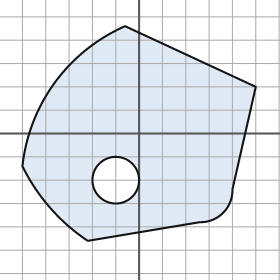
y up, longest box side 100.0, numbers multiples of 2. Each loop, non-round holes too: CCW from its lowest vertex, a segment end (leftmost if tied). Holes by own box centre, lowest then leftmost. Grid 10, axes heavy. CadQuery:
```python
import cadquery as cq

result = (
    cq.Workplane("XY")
    .moveTo(-22.0, -46.0)
    .lineTo(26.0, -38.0)
    .threePointArc((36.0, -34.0), (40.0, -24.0))
    .lineTo(50.0, 20.0)
    .lineTo(-6.0, 46.0)
    .threePointArc((-36.0, 22.0), (-50.0, -14.0))
    .threePointArc((-38.0, -32.0), (-22.0, -46.0))
    .close()
    .moveTo(-10.0, -20.0)
    .circle(10.0)
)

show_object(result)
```